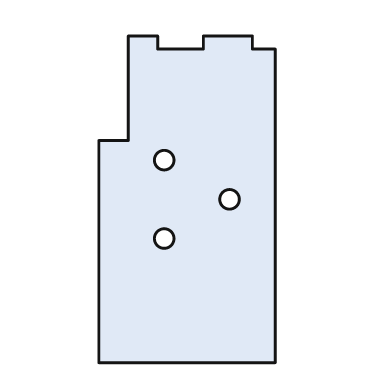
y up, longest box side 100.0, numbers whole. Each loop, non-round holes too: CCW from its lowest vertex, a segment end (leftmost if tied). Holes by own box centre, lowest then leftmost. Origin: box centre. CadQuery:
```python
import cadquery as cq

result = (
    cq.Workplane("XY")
    .moveTo(-27.0, -50.0)
    .lineTo(27.0, -50.0)
    .lineTo(27.0, 46.0)
    .lineTo(20.0, 46.0)
    .lineTo(20.0, 50.0)
    .lineTo(5.0, 50.0)
    .lineTo(5.0, 46.0)
    .lineTo(-9.0, 46.0)
    .lineTo(-9.0, 50.0)
    .lineTo(-18.0, 50.0)
    .lineTo(-18.0, 18.0)
    .lineTo(-27.0, 18.0)
    .close()
    .moveTo(-7.0, -12.0)
    .circle(3.0)
    .moveTo(13.0, 0.0)
    .circle(3.0)
    .moveTo(-7.0, 12.0)
    .circle(3.0)
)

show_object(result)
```